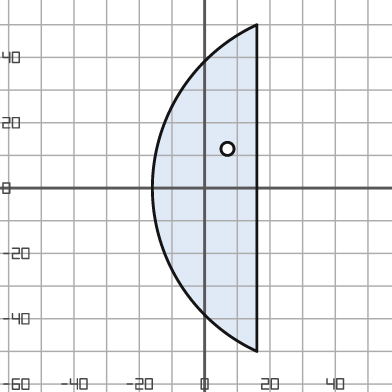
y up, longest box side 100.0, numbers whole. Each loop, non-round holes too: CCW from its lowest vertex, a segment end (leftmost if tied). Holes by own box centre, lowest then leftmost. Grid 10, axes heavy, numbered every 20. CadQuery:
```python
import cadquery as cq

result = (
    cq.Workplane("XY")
    .moveTo(16.0, -50.0)
    .lineTo(16.0, 50.0)
    .threePointArc((-16.0, 0.0), (16.0, -50.0))
    .close()
    .moveTo(7.0, 12.0)
    .circle(2.0)
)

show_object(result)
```